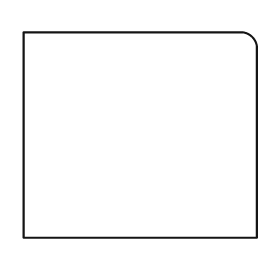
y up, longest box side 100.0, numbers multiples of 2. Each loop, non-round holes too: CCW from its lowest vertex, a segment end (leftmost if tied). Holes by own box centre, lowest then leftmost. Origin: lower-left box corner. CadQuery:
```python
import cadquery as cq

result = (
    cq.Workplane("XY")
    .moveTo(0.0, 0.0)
    .lineTo(100.0, 0.0)
    .lineTo(100.0, 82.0)
    .threePointArc((98.0, 86.0), (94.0, 88.0))
    .lineTo(0.0, 88.0)
    .close()
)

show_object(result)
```